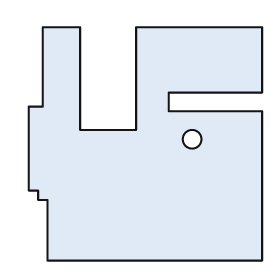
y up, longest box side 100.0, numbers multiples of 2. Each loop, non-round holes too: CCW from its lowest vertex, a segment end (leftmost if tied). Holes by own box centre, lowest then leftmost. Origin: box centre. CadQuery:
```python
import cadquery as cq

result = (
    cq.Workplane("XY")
    .moveTo(-42.0, -50.0)
    .lineTo(50.0, -50.0)
    .lineTo(50.0, 14.0)
    .lineTo(10.0, 14.0)
    .lineTo(10.0, 22.0)
    .lineTo(50.0, 22.0)
    .lineTo(50.0, 50.0)
    .lineTo(-4.0, 50.0)
    .lineTo(-4.0, 6.0)
    .lineTo(-28.0, 6.0)
    .lineTo(-28.0, 50.0)
    .lineTo(-44.0, 50.0)
    .lineTo(-44.0, 16.0)
    .lineTo(-50.0, 16.0)
    .lineTo(-50.0, -20.0)
    .lineTo(-46.0, -20.0)
    .lineTo(-46.0, -24.0)
    .lineTo(-42.0, -24.0)
    .close()
    .moveTo(20.0, 2.0)
    .circle(4.0)
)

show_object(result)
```